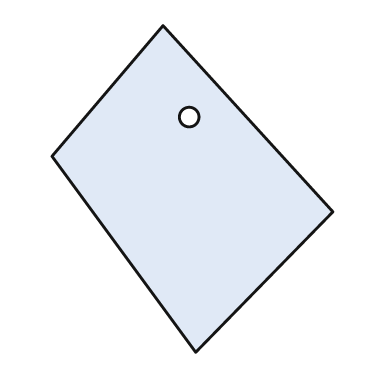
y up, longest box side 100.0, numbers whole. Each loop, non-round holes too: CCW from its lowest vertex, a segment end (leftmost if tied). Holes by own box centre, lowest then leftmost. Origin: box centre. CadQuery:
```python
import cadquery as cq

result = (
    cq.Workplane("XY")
    .moveTo(1.0, -50.0)
    .lineTo(43.0, -7.0)
    .lineTo(-9.0, 50.0)
    .lineTo(-43.0, 10.0)
    .close()
    .moveTo(-1.0, 22.0)
    .circle(3.0)
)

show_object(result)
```